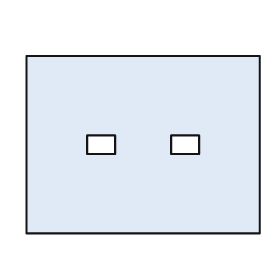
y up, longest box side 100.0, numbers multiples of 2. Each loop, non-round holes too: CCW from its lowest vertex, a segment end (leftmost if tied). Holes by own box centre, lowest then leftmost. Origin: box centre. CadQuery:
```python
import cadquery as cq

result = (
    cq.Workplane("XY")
    .moveTo(-50.0, -38.0)
    .lineTo(50.0, -38.0)
    .lineTo(50.0, 38.0)
    .lineTo(-50.0, 38.0)
    .close()
    .moveTo(-24.0, -4.0)
    .lineTo(-12.0, -4.0)
    .lineTo(-12.0, 4.0)
    .lineTo(-24.0, 4.0)
    .close()
    .moveTo(12.0, -4.0)
    .lineTo(24.0, -4.0)
    .lineTo(24.0, 4.0)
    .lineTo(12.0, 4.0)
    .close()
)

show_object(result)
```